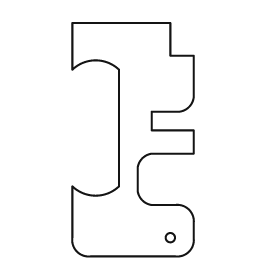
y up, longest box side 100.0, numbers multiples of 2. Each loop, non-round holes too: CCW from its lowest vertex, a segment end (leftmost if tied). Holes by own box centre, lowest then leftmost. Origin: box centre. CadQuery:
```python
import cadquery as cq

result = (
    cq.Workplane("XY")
    .moveTo(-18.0, -50.0)
    .lineTo(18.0, -50.0)
    .threePointArc((24.0, -48.0), (26.0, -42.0))
    .lineTo(26.0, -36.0)
    .threePointArc((24.0, -30.0), (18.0, -28.0))
    .lineTo(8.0, -28.0)
    .threePointArc((4.0, -26.0), (2.0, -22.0))
    .lineTo(2.0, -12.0)
    .threePointArc((4.0, -8.0), (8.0, -6.0))
    .lineTo(26.0, -6.0)
    .lineTo(26.0, 4.0)
    .lineTo(8.0, 4.0)
    .lineTo(8.0, 12.0)
    .lineTo(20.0, 12.0)
    .threePointArc((24.0, 14.0), (26.0, 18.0))
    .lineTo(26.0, 36.0)
    .lineTo(16.0, 36.0)
    .lineTo(16.0, 50.0)
    .lineTo(-26.0, 50.0)
    .lineTo(-26.0, 30.0)
    .threePointArc((-16.0, 34.0), (-6.0, 30.0))
    .lineTo(-6.0, -20.0)
    .threePointArc((-16.0, -24.0), (-26.0, -20.0))
    .lineTo(-26.0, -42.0)
    .threePointArc((-24.0, -48.0), (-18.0, -50.0))
    .close()
    .moveTo(16.0, -42.0)
    .circle(2.0)
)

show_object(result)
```